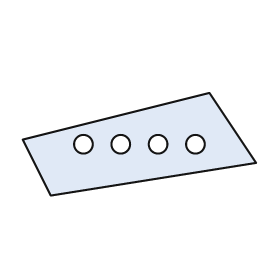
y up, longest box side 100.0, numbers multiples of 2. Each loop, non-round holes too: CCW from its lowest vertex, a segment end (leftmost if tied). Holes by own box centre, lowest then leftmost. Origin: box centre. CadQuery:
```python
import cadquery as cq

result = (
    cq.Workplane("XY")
    .moveTo(-38.0, -22.0)
    .lineTo(50.0, -8.0)
    .lineTo(30.0, 22.0)
    .lineTo(-50.0, 2.0)
    .close()
    .moveTo(-24.0, 0.0)
    .circle(4.0)
    .moveTo(-8.0, 0.0)
    .circle(4.0)
    .moveTo(8.0, 0.0)
    .circle(4.0)
    .moveTo(24.0, 0.0)
    .circle(4.0)
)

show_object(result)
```